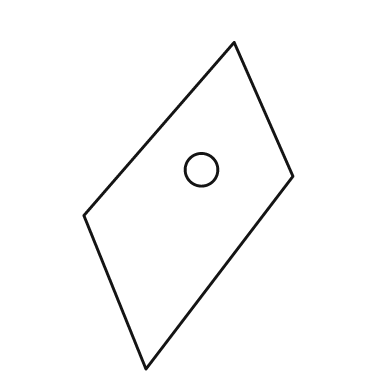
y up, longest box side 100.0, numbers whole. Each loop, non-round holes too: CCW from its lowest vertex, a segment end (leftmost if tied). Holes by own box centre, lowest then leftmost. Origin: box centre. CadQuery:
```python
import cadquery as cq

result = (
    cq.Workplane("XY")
    .moveTo(-13.0, -50.0)
    .lineTo(32.0, 9.0)
    .lineTo(14.0, 50.0)
    .lineTo(-32.0, -3.0)
    .close()
    .moveTo(4.0, 11.0)
    .circle(5.0)
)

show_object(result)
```